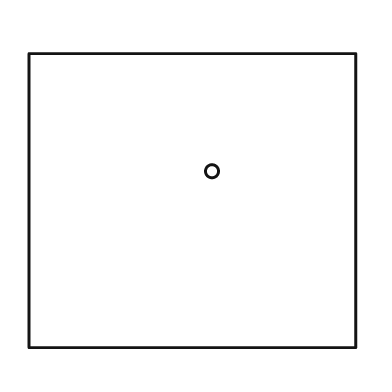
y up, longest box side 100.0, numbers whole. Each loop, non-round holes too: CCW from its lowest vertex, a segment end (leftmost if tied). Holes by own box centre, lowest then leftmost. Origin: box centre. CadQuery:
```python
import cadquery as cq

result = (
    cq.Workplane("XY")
    .moveTo(-50.0, -45.0)
    .lineTo(50.0, -45.0)
    .lineTo(50.0, 45.0)
    .lineTo(-50.0, 45.0)
    .close()
    .moveTo(6.0, 9.0)
    .circle(2.0)
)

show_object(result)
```